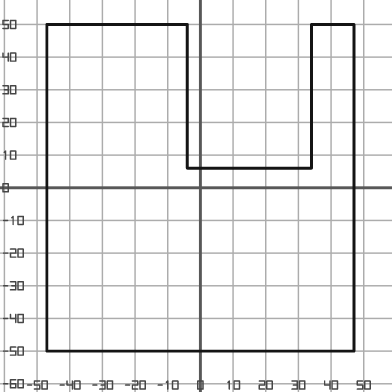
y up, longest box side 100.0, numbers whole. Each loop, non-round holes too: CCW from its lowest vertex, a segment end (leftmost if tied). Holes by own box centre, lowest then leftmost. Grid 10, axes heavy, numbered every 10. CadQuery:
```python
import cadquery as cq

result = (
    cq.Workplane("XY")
    .moveTo(-47.0, -50.0)
    .lineTo(47.0, -50.0)
    .lineTo(47.0, 50.0)
    .lineTo(34.0, 50.0)
    .lineTo(34.0, 6.0)
    .lineTo(-4.0, 6.0)
    .lineTo(-4.0, 50.0)
    .lineTo(-47.0, 50.0)
    .close()
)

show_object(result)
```